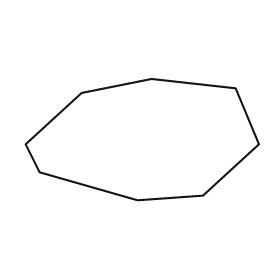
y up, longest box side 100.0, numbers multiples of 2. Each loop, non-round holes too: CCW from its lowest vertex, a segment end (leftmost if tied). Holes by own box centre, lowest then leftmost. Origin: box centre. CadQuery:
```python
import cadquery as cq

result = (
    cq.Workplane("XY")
    .moveTo(-2.0, -26.0)
    .lineTo(26.0, -24.0)
    .lineTo(50.0, -2.0)
    .lineTo(40.0, 22.0)
    .lineTo(4.0, 26.0)
    .lineTo(-26.0, 20.0)
    .lineTo(-50.0, -2.0)
    .lineTo(-44.0, -14.0)
    .close()
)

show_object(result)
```